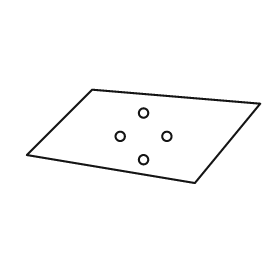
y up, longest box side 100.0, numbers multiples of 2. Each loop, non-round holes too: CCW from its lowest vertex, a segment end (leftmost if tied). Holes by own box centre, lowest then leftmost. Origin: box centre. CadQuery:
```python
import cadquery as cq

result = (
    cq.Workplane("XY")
    .moveTo(22.0, -20.0)
    .lineTo(50.0, 14.0)
    .lineTo(-22.0, 20.0)
    .lineTo(-50.0, -8.0)
    .close()
    .moveTo(0.0, -10.0)
    .circle(2.0)
    .moveTo(-10.0, 0.0)
    .circle(2.0)
    .moveTo(10.0, 0.0)
    .circle(2.0)
    .moveTo(0.0, 10.0)
    .circle(2.0)
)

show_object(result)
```